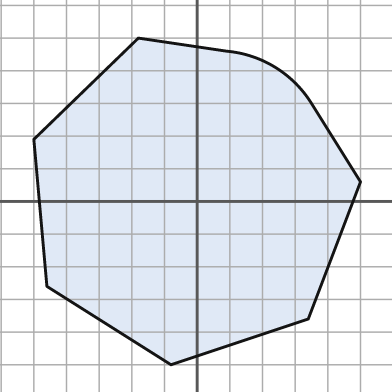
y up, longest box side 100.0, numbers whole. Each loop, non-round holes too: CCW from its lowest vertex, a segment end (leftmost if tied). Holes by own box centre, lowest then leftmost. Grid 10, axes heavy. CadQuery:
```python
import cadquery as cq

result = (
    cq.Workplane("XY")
    .moveTo(-8.0, -50.0)
    .lineTo(34.0, -36.0)
    .lineTo(50.0, 6.0)
    .lineTo(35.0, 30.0)
    .threePointArc((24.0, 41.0), (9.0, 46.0))
    .lineTo(-18.0, 50.0)
    .lineTo(-50.0, 19.0)
    .lineTo(-46.0, -26.0)
    .close()
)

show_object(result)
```